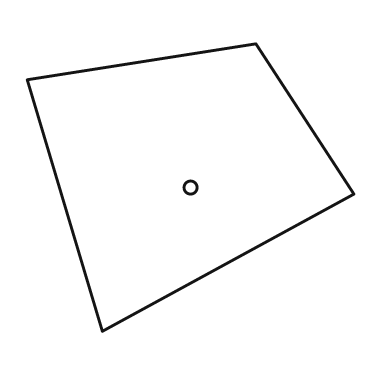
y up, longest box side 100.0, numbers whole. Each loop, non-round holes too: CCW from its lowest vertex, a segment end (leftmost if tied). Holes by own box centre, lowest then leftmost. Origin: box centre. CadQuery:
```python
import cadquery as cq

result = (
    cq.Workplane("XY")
    .moveTo(-27.0, -44.0)
    .lineTo(50.0, -2.0)
    .lineTo(20.0, 44.0)
    .lineTo(-50.0, 33.0)
    .close()
    .moveTo(0.0, 0.0)
    .circle(2.0)
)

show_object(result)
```